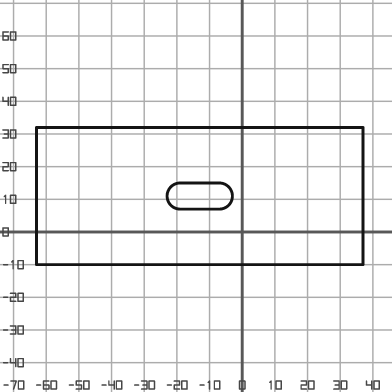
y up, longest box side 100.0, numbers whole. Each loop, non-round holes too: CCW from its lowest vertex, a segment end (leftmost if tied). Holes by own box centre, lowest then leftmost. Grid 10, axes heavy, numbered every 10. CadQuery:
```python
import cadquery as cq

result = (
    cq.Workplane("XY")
    .moveTo(-63.0, -10.0)
    .lineTo(37.0, -10.0)
    .lineTo(37.0, 32.0)
    .lineTo(-63.0, 32.0)
    .close()
    .moveTo(-19.0, 7.0)
    .lineTo(-7.0, 7.0)
    .threePointArc((-3.0, 11.0), (-7.0, 15.0))
    .lineTo(-19.0, 15.0)
    .threePointArc((-23.0, 11.0), (-19.0, 7.0))
    .close()
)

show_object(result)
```